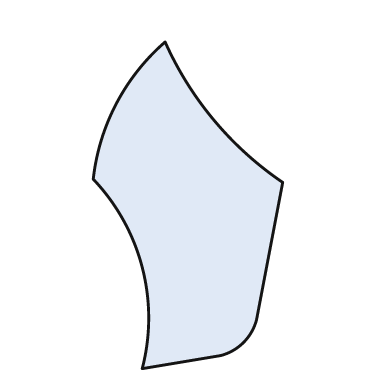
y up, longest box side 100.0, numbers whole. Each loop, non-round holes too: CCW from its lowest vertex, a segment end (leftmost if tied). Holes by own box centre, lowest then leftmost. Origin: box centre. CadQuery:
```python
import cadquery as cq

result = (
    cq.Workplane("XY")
    .moveTo(-14.0, -50.0)
    .lineTo(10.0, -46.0)
    .threePointArc((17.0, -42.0), (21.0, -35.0))
    .lineTo(29.0, 7.0)
    .threePointArc((8.0, 26.0), (-7.0, 50.0))
    .threePointArc((-22.0, 31.0), (-29.0, 8.0))
    .threePointArc((-14.0, -19.0), (-14.0, -50.0))
    .close()
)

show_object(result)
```